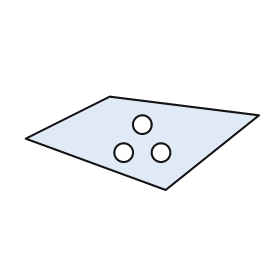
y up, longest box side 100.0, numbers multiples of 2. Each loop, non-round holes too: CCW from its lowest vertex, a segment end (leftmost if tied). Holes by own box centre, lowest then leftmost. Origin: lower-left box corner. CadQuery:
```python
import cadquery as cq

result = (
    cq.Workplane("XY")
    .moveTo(60.0, 0.0)
    .lineTo(100.0, 32.0)
    .lineTo(36.0, 40.0)
    .lineTo(0.0, 22.0)
    .close()
    .moveTo(42.0, 16.0)
    .circle(4.0)
    .moveTo(58.0, 16.0)
    .circle(4.0)
    .moveTo(50.0, 28.0)
    .circle(4.0)
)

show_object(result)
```